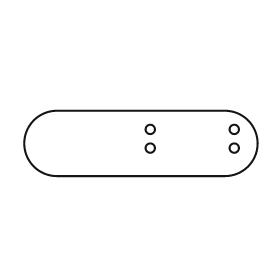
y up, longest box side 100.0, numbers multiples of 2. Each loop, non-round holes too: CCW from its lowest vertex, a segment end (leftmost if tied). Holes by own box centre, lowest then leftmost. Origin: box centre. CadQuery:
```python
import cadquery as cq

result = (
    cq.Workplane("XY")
    .moveTo(-36.0, -14.0)
    .lineTo(36.0, -14.0)
    .threePointArc((50.0, 0.0), (36.0, 14.0))
    .lineTo(-36.0, 14.0)
    .threePointArc((-50.0, 0.0), (-36.0, -14.0))
    .close()
    .moveTo(4.0, -2.0)
    .circle(2.0)
    .moveTo(40.0, -2.0)
    .circle(2.0)
    .moveTo(4.0, 6.0)
    .circle(2.0)
    .moveTo(40.0, 6.0)
    .circle(2.0)
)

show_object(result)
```